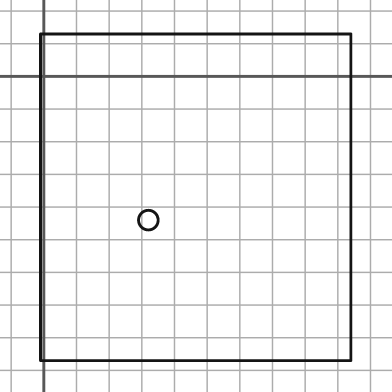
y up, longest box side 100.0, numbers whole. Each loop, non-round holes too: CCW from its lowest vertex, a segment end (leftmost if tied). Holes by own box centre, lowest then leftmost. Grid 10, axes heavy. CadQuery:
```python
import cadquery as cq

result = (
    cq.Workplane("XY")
    .moveTo(-1.0, -87.0)
    .lineTo(94.0, -87.0)
    .lineTo(94.0, 13.0)
    .lineTo(-1.0, 13.0)
    .close()
    .moveTo(32.0, -44.0)
    .circle(3.0)
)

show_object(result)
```